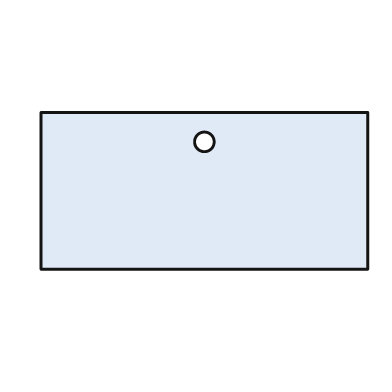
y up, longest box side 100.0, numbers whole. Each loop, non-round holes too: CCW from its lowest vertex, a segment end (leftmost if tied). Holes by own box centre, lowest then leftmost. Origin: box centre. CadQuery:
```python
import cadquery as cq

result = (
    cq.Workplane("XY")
    .moveTo(-50.0, -24.0)
    .lineTo(50.0, -24.0)
    .lineTo(50.0, 24.0)
    .lineTo(-50.0, 24.0)
    .close()
    .moveTo(0.0, 15.0)
    .circle(3.0)
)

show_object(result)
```